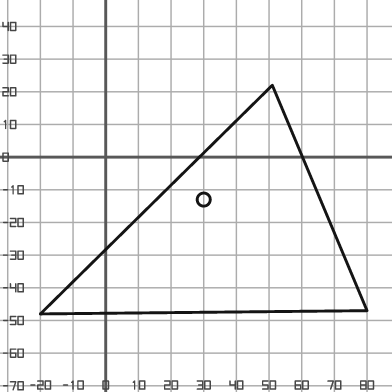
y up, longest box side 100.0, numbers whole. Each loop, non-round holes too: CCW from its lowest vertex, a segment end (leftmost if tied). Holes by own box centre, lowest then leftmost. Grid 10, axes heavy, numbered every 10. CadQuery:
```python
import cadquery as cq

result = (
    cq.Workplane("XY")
    .moveTo(-20.0, -48.0)
    .lineTo(80.0, -47.0)
    .lineTo(51.0, 22.0)
    .close()
    .moveTo(30.0, -13.0)
    .circle(2.0)
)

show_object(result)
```